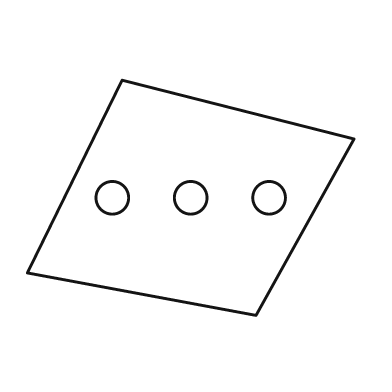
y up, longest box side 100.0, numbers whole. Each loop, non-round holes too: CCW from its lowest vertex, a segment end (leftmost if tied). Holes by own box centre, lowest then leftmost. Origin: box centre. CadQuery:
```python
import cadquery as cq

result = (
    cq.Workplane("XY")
    .moveTo(20.0, -36.0)
    .lineTo(50.0, 18.0)
    .lineTo(-21.0, 36.0)
    .lineTo(-50.0, -23.0)
    .close()
    .moveTo(-24.0, 0.0)
    .circle(5.0)
    .moveTo(0.0, 0.0)
    .circle(5.0)
    .moveTo(24.0, 0.0)
    .circle(5.0)
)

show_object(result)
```